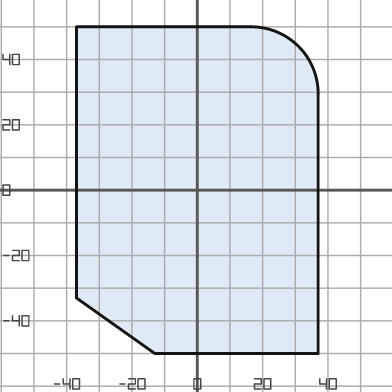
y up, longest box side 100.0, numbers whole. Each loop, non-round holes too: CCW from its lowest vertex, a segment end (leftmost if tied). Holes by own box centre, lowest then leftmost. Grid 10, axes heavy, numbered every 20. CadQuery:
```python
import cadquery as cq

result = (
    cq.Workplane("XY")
    .moveTo(-13.0, -50.0)
    .lineTo(37.0, -50.0)
    .lineTo(37.0, 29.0)
    .threePointArc((31.0, 44.0), (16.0, 50.0))
    .lineTo(-37.0, 50.0)
    .lineTo(-37.0, -33.0)
    .close()
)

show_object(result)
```